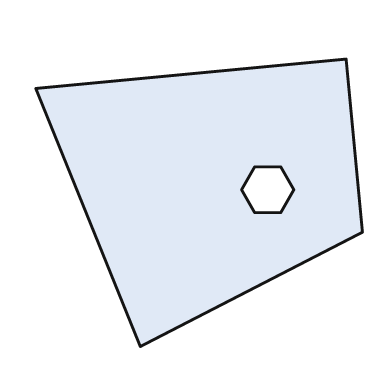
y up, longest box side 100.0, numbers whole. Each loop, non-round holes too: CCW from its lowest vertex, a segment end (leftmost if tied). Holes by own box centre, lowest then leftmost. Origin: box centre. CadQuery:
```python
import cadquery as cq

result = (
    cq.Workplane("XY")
    .moveTo(-18.0, -44.0)
    .lineTo(50.0, -9.0)
    .lineTo(45.0, 44.0)
    .lineTo(-50.0, 35.0)
    .close()
    .moveTo(17.0, -3.0)
    .lineTo(25.0, -3.0)
    .lineTo(29.0, 4.0)
    .lineTo(25.0, 11.0)
    .lineTo(17.0, 11.0)
    .lineTo(13.0, 4.0)
    .close()
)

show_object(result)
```